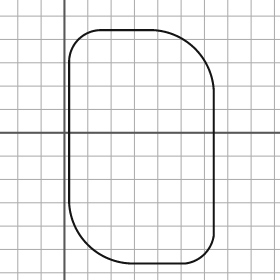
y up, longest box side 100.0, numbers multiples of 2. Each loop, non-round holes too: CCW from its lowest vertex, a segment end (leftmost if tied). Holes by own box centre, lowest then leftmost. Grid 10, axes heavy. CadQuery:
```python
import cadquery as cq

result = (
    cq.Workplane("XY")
    .moveTo(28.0, -56.0)
    .lineTo(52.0, -56.0)
    .threePointArc((60.0, -52.0), (64.0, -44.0))
    .lineTo(64.0, 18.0)
    .threePointArc((56.0, 36.0), (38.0, 44.0))
    .lineTo(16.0, 44.0)
    .threePointArc((6.0, 40.0), (2.0, 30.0))
    .lineTo(2.0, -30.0)
    .threePointArc((10.0, -48.0), (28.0, -56.0))
    .close()
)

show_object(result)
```